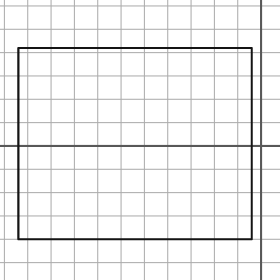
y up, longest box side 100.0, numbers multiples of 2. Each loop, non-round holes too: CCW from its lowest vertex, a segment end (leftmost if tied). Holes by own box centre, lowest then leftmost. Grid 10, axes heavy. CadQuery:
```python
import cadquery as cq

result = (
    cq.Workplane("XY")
    .moveTo(-104.0, -40.0)
    .lineTo(-4.0, -40.0)
    .lineTo(-4.0, 42.0)
    .lineTo(-104.0, 42.0)
    .close()
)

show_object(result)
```